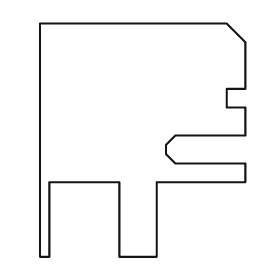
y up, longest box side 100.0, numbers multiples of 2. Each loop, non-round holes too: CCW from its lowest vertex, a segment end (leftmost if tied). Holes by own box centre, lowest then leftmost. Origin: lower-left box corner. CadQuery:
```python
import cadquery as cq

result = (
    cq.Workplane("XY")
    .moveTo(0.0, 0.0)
    .lineTo(4.0, 0.0)
    .lineTo(4.0, 32.0)
    .lineTo(34.0, 32.0)
    .lineTo(34.0, 0.0)
    .lineTo(50.0, 0.0)
    .lineTo(50.0, 32.0)
    .lineTo(88.0, 32.0)
    .lineTo(88.0, 40.0)
    .lineTo(58.0, 40.0)
    .lineTo(54.0, 44.0)
    .lineTo(54.0, 48.0)
    .lineTo(58.0, 52.0)
    .lineTo(88.0, 52.0)
    .lineTo(88.0, 64.0)
    .lineTo(80.0, 64.0)
    .lineTo(80.0, 72.0)
    .lineTo(88.0, 72.0)
    .lineTo(88.0, 92.0)
    .lineTo(80.0, 100.0)
    .lineTo(0.0, 100.0)
    .close()
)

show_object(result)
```